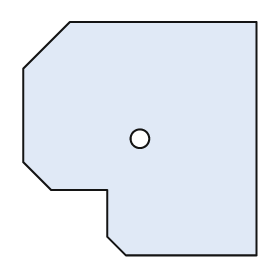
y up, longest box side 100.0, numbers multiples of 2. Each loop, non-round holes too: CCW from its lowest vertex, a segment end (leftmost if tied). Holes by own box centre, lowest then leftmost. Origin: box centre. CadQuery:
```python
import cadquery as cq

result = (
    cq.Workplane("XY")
    .moveTo(-6.0, -50.0)
    .lineTo(50.0, -50.0)
    .lineTo(50.0, 50.0)
    .lineTo(-30.0, 50.0)
    .lineTo(-50.0, 30.0)
    .lineTo(-50.0, -10.0)
    .lineTo(-38.0, -22.0)
    .lineTo(-14.0, -22.0)
    .lineTo(-14.0, -42.0)
    .close()
    .moveTo(0.0, 0.0)
    .circle(4.0)
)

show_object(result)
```